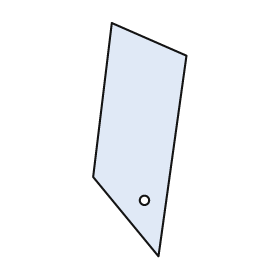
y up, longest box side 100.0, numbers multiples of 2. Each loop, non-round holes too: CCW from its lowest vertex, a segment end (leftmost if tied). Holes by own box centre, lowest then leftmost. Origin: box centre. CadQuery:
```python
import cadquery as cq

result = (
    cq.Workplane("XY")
    .moveTo(8.0, -50.0)
    .lineTo(20.0, 36.0)
    .lineTo(-12.0, 50.0)
    .lineTo(-20.0, -16.0)
    .close()
    .moveTo(2.0, -26.0)
    .circle(2.0)
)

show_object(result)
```